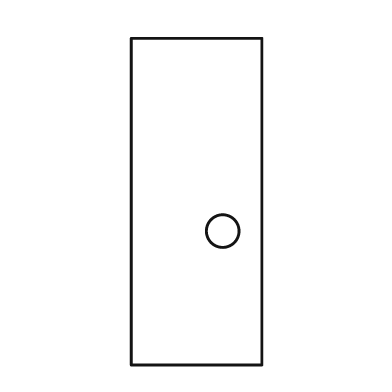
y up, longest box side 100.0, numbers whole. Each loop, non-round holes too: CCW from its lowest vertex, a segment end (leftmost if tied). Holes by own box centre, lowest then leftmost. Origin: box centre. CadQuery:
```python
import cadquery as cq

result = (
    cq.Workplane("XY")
    .moveTo(-20.0, -50.0)
    .lineTo(20.0, -50.0)
    .lineTo(20.0, 50.0)
    .lineTo(-20.0, 50.0)
    .close()
    .moveTo(8.0, -9.0)
    .circle(5.0)
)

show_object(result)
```